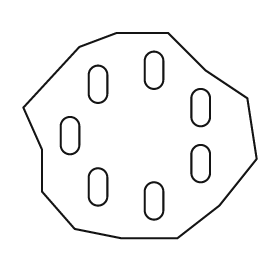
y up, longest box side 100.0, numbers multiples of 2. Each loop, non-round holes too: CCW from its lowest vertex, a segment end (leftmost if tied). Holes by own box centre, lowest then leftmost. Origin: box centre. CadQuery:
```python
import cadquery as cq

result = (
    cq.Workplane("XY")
    .moveTo(-8.0, -44.0)
    .lineTo(16.0, -44.0)
    .lineTo(34.0, -30.0)
    .lineTo(50.0, -10.0)
    .lineTo(46.0, 16.0)
    .lineTo(28.0, 28.0)
    .lineTo(12.0, 44.0)
    .lineTo(-10.0, 44.0)
    .lineTo(-26.0, 38.0)
    .lineTo(-50.0, 12.0)
    .lineTo(-42.0, -6.0)
    .lineTo(-42.0, -24.0)
    .lineTo(-28.0, -40.0)
    .close()
    .moveTo(2.0, -32.0)
    .threePointArc((6.0, -36.0), (10.0, -32.0))
    .lineTo(10.0, -24.0)
    .threePointArc((6.0, -20.0), (2.0, -24.0))
    .close()
    .moveTo(-22.0, -26.0)
    .threePointArc((-18.0, -30.0), (-14.0, -26.0))
    .lineTo(-14.0, -18.0)
    .threePointArc((-18.0, -14.0), (-22.0, -18.0))
    .close()
    .moveTo(22.0, -16.0)
    .threePointArc((26.0, -20.0), (30.0, -16.0))
    .lineTo(30.0, -8.0)
    .threePointArc((26.0, -4.0), (22.0, -8.0))
    .close()
    .moveTo(-34.0, -4.0)
    .threePointArc((-30.0, -8.0), (-26.0, -4.0))
    .lineTo(-26.0, 4.0)
    .threePointArc((-30.0, 8.0), (-34.0, 4.0))
    .close()
    .moveTo(22.0, 8.0)
    .threePointArc((26.0, 4.0), (30.0, 8.0))
    .lineTo(30.0, 16.0)
    .threePointArc((26.0, 20.0), (22.0, 16.0))
    .close()
    .moveTo(-22.0, 18.0)
    .threePointArc((-18.0, 14.0), (-14.0, 18.0))
    .lineTo(-14.0, 26.0)
    .threePointArc((-18.0, 30.0), (-22.0, 26.0))
    .close()
    .moveTo(2.0, 24.0)
    .threePointArc((6.0, 20.0), (10.0, 24.0))
    .lineTo(10.0, 32.0)
    .threePointArc((6.0, 36.0), (2.0, 32.0))
    .close()
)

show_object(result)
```